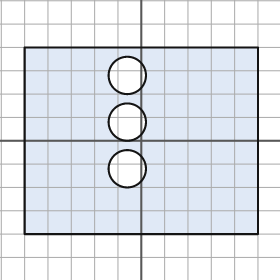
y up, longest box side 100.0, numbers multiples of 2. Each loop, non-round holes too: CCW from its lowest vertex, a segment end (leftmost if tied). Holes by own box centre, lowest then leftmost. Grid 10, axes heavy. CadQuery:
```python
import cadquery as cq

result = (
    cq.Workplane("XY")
    .moveTo(-50.0, -40.0)
    .lineTo(50.0, -40.0)
    .lineTo(50.0, 40.0)
    .lineTo(-50.0, 40.0)
    .close()
    .moveTo(-6.0, -12.0)
    .circle(8.0)
    .moveTo(-6.0, 8.0)
    .circle(8.0)
    .moveTo(-6.0, 28.0)
    .circle(8.0)
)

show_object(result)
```